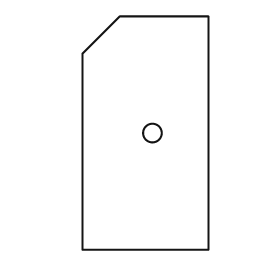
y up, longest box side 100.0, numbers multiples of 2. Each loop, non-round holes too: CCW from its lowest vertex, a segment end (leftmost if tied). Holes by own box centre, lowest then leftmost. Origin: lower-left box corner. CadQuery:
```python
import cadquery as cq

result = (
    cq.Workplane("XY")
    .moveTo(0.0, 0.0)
    .lineTo(54.0, 0.0)
    .lineTo(54.0, 100.0)
    .lineTo(16.0, 100.0)
    .lineTo(0.0, 84.0)
    .close()
    .moveTo(30.0, 50.0)
    .circle(4.0)
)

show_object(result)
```